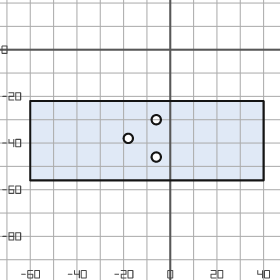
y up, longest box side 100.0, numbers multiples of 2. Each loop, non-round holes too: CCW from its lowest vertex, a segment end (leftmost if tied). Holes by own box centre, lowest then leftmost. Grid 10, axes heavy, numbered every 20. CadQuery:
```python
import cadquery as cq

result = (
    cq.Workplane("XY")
    .moveTo(-60.0, -56.0)
    .lineTo(40.0, -56.0)
    .lineTo(40.0, -22.0)
    .lineTo(-60.0, -22.0)
    .close()
    .moveTo(-6.0, -46.0)
    .circle(2.0)
    .moveTo(-18.0, -38.0)
    .circle(2.0)
    .moveTo(-6.0, -30.0)
    .circle(2.0)
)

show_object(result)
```